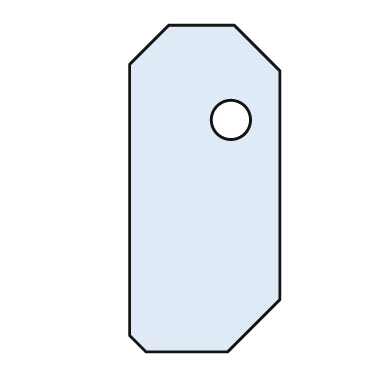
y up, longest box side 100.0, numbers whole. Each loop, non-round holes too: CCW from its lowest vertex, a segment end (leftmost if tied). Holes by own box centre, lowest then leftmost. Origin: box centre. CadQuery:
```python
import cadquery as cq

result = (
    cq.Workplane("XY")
    .moveTo(-18.0, -50.0)
    .lineTo(7.0, -50.0)
    .lineTo(23.0, -34.0)
    .lineTo(23.0, 36.0)
    .lineTo(9.0, 50.0)
    .lineTo(-11.0, 50.0)
    .lineTo(-23.0, 38.0)
    .lineTo(-23.0, -45.0)
    .close()
    .moveTo(8.0, 21.0)
    .circle(6.0)
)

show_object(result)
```